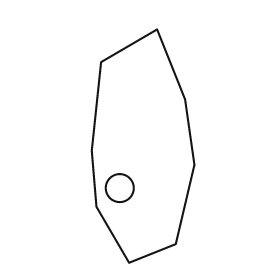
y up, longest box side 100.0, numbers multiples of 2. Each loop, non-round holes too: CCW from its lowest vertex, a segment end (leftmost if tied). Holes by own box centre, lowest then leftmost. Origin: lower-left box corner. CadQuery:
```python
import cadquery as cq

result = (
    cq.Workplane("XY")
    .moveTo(16.0, 0.0)
    .lineTo(36.0, 8.0)
    .lineTo(44.0, 42.0)
    .lineTo(40.0, 70.0)
    .lineTo(28.0, 100.0)
    .lineTo(4.0, 86.0)
    .lineTo(0.0, 48.0)
    .lineTo(2.0, 24.0)
    .close()
    .moveTo(12.0, 32.0)
    .circle(6.0)
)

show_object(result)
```